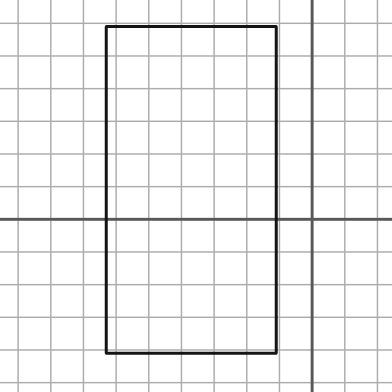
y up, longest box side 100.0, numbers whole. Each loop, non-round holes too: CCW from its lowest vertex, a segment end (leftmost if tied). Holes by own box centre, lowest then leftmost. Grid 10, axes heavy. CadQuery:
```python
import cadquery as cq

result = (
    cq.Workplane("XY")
    .moveTo(-63.0, -41.0)
    .lineTo(-11.0, -41.0)
    .lineTo(-11.0, 59.0)
    .lineTo(-63.0, 59.0)
    .close()
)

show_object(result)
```